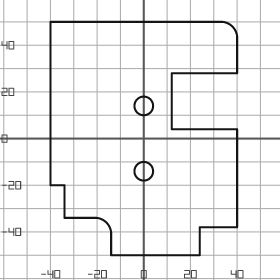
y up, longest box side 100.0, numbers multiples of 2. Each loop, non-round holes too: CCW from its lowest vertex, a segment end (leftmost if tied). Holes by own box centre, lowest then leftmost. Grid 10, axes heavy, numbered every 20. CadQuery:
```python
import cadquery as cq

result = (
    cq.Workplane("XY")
    .moveTo(-14.0, -50.0)
    .lineTo(24.0, -50.0)
    .lineTo(24.0, -38.0)
    .lineTo(40.0, -38.0)
    .lineTo(40.0, 4.0)
    .lineTo(12.0, 4.0)
    .lineTo(12.0, 28.0)
    .lineTo(40.0, 28.0)
    .lineTo(40.0, 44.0)
    .threePointArc((38.0, 48.0), (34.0, 50.0))
    .lineTo(-40.0, 50.0)
    .lineTo(-40.0, -20.0)
    .lineTo(-34.0, -20.0)
    .lineTo(-34.0, -34.0)
    .lineTo(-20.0, -34.0)
    .threePointArc((-16.0, -36.0), (-14.0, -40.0))
    .close()
    .moveTo(0.0, -14.0)
    .circle(4.0)
    .moveTo(0.0, 14.0)
    .circle(4.0)
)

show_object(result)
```